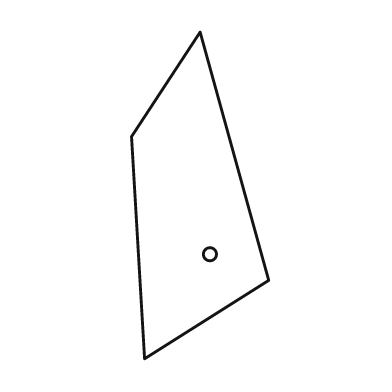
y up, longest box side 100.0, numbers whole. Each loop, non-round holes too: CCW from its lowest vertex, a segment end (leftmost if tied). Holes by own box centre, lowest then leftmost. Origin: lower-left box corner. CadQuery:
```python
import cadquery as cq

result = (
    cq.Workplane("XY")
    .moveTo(4.0, 0.0)
    .lineTo(42.0, 24.0)
    .lineTo(21.0, 100.0)
    .lineTo(0.0, 68.0)
    .close()
    .moveTo(24.0, 32.0)
    .circle(2.0)
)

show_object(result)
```